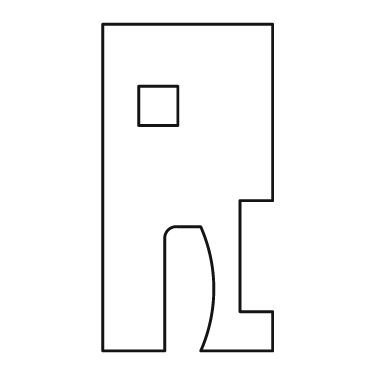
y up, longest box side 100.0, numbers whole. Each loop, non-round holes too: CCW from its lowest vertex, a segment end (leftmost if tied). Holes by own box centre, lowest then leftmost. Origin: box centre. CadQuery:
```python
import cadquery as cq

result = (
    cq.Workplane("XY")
    .moveTo(-26.0, -50.0)
    .lineTo(-7.0, -50.0)
    .lineTo(-7.0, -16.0)
    .threePointArc((-6.0, -13.0), (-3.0, -12.0))
    .lineTo(4.0, -12.0)
    .threePointArc((8.0, -31.0), (4.0, -50.0))
    .lineTo(26.0, -50.0)
    .lineTo(26.0, -38.0)
    .lineTo(16.0, -38.0)
    .lineTo(16.0, -4.0)
    .lineTo(26.0, -4.0)
    .lineTo(26.0, 50.0)
    .lineTo(-26.0, 50.0)
    .close()
    .moveTo(-15.0, 19.0)
    .lineTo(-3.0, 19.0)
    .lineTo(-3.0, 31.0)
    .lineTo(-15.0, 31.0)
    .close()
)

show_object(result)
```